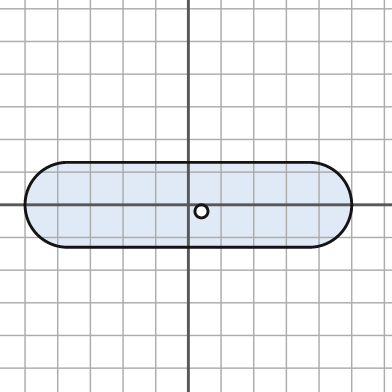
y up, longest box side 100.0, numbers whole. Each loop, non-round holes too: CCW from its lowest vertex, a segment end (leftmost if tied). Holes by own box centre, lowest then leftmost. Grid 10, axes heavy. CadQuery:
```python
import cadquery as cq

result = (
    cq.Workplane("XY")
    .moveTo(-37.0, -13.0)
    .lineTo(37.0, -13.0)
    .threePointArc((50.0, 0.0), (37.0, 13.0))
    .lineTo(-37.0, 13.0)
    .threePointArc((-50.0, 0.0), (-37.0, -13.0))
    .close()
    .moveTo(4.0, -2.0)
    .circle(2.0)
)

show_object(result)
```